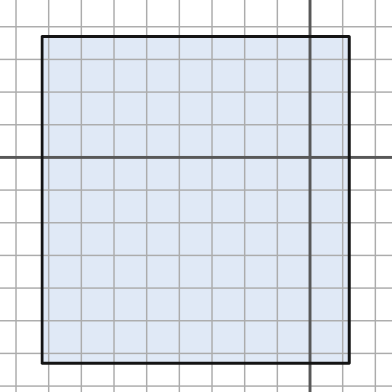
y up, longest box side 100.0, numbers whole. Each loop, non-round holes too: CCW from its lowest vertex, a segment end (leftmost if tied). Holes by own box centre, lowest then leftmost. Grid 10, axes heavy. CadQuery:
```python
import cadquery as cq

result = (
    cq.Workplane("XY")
    .moveTo(-82.0, -63.0)
    .lineTo(12.0, -63.0)
    .lineTo(12.0, 37.0)
    .lineTo(-82.0, 37.0)
    .close()
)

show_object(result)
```